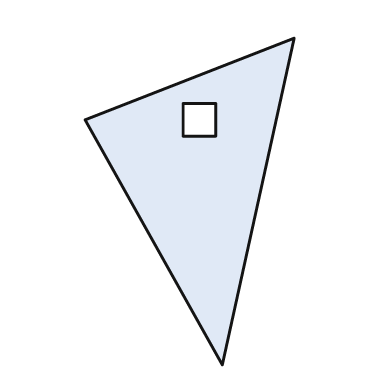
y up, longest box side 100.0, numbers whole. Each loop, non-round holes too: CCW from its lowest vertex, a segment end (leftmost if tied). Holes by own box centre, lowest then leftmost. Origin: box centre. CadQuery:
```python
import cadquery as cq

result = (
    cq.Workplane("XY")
    .moveTo(10.0, -50.0)
    .lineTo(32.0, 50.0)
    .lineTo(-32.0, 25.0)
    .close()
    .moveTo(-2.0, 20.0)
    .lineTo(8.0, 20.0)
    .lineTo(8.0, 30.0)
    .lineTo(-2.0, 30.0)
    .close()
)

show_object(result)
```